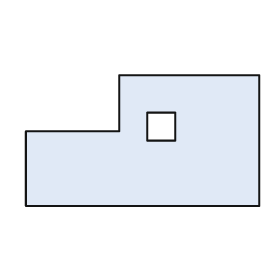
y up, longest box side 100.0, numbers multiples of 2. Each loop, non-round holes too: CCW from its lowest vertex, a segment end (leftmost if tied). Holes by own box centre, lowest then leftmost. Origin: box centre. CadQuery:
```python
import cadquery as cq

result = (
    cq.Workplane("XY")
    .moveTo(-50.0, -28.0)
    .lineTo(50.0, -28.0)
    .lineTo(50.0, 28.0)
    .lineTo(-10.0, 28.0)
    .lineTo(-10.0, 4.0)
    .lineTo(-50.0, 4.0)
    .close()
    .moveTo(2.0, 0.0)
    .lineTo(14.0, 0.0)
    .lineTo(14.0, 12.0)
    .lineTo(2.0, 12.0)
    .close()
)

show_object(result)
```